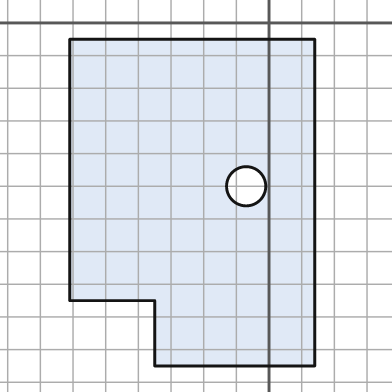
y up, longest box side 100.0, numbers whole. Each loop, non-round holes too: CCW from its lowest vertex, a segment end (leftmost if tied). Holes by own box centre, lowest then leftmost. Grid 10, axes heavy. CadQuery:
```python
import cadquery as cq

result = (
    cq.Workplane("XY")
    .moveTo(-35.0, -105.0)
    .lineTo(14.0, -105.0)
    .lineTo(14.0, -5.0)
    .lineTo(-61.0, -5.0)
    .lineTo(-61.0, -85.0)
    .lineTo(-35.0, -85.0)
    .close()
    .moveTo(-7.0, -50.0)
    .circle(6.0)
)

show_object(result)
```